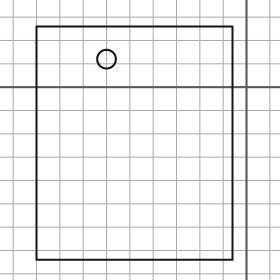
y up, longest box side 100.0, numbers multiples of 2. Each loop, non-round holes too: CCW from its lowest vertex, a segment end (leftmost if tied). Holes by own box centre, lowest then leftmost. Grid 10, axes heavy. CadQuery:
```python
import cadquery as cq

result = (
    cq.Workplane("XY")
    .moveTo(-90.0, -74.0)
    .lineTo(-6.0, -74.0)
    .lineTo(-6.0, 26.0)
    .lineTo(-90.0, 26.0)
    .close()
    .moveTo(-60.0, 12.0)
    .circle(4.0)
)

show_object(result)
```